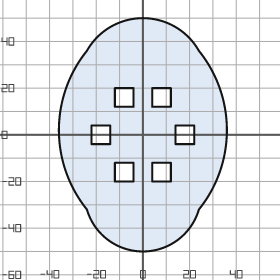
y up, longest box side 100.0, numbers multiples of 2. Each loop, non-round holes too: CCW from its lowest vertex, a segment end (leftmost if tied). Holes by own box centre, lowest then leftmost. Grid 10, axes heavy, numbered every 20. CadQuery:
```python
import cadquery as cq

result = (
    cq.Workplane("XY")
    .moveTo(-24.0, -32.0)
    .threePointArc((0.0, -50.0), (24.0, -32.0))
    .threePointArc((36.0, 2.0), (24.0, 36.0))
    .threePointArc((0.0, 50.0), (-24.0, 36.0))
    .threePointArc((-36.0, 2.0), (-24.0, -32.0))
    .close()
    .moveTo(-12.0, -20.0)
    .lineTo(-4.0, -20.0)
    .lineTo(-4.0, -12.0)
    .lineTo(-12.0, -12.0)
    .close()
    .moveTo(4.0, -20.0)
    .lineTo(12.0, -20.0)
    .lineTo(12.0, -12.0)
    .lineTo(4.0, -12.0)
    .close()
    .moveTo(-22.0, -4.0)
    .lineTo(-14.0, -4.0)
    .lineTo(-14.0, 4.0)
    .lineTo(-22.0, 4.0)
    .close()
    .moveTo(14.0, -4.0)
    .lineTo(22.0, -4.0)
    .lineTo(22.0, 4.0)
    .lineTo(14.0, 4.0)
    .close()
    .moveTo(-12.0, 12.0)
    .lineTo(-4.0, 12.0)
    .lineTo(-4.0, 20.0)
    .lineTo(-12.0, 20.0)
    .close()
    .moveTo(4.0, 12.0)
    .lineTo(12.0, 12.0)
    .lineTo(12.0, 20.0)
    .lineTo(4.0, 20.0)
    .close()
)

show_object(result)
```